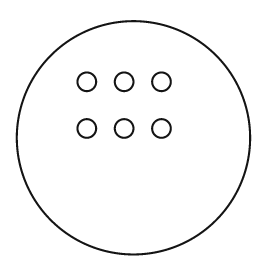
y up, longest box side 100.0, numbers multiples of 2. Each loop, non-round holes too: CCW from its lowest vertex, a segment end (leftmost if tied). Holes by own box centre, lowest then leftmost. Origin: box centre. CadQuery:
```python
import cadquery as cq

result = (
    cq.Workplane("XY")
    .moveTo(0.0, 0.0)
    .circle(50.0)
    .moveTo(-20.0, 4.0)
    .circle(4.0)
    .moveTo(-4.0, 4.0)
    .circle(4.0)
    .moveTo(12.0, 4.0)
    .circle(4.0)
    .moveTo(-20.0, 24.0)
    .circle(4.0)
    .moveTo(-4.0, 24.0)
    .circle(4.0)
    .moveTo(12.0, 24.0)
    .circle(4.0)
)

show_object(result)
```